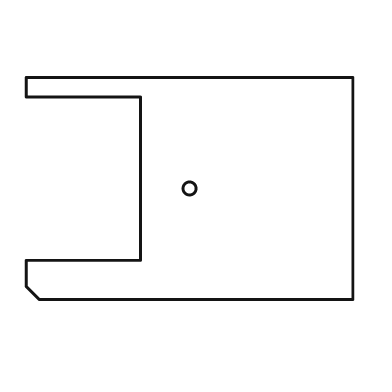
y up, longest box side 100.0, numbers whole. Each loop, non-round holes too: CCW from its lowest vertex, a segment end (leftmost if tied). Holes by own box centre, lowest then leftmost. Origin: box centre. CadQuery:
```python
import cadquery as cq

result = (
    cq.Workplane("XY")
    .moveTo(-46.0, -34.0)
    .lineTo(50.0, -34.0)
    .lineTo(50.0, 34.0)
    .lineTo(-50.0, 34.0)
    .lineTo(-50.0, 28.0)
    .lineTo(-15.0, 28.0)
    .lineTo(-15.0, -22.0)
    .lineTo(-50.0, -22.0)
    .lineTo(-50.0, -30.0)
    .close()
    .moveTo(0.0, 0.0)
    .circle(2.0)
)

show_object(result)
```